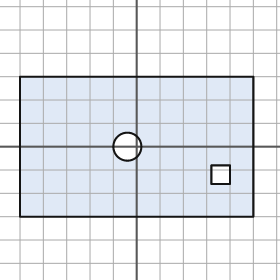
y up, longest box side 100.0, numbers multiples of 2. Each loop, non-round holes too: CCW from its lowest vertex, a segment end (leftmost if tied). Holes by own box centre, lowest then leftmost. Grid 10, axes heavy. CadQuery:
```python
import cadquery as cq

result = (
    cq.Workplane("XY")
    .moveTo(-50.0, -30.0)
    .lineTo(50.0, -30.0)
    .lineTo(50.0, 30.0)
    .lineTo(-50.0, 30.0)
    .close()
    .moveTo(32.0, -16.0)
    .lineTo(40.0, -16.0)
    .lineTo(40.0, -8.0)
    .lineTo(32.0, -8.0)
    .close()
    .moveTo(-4.0, 0.0)
    .circle(6.0)
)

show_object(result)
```